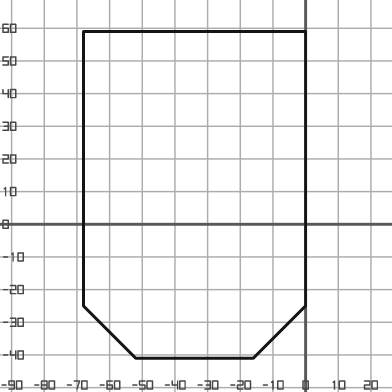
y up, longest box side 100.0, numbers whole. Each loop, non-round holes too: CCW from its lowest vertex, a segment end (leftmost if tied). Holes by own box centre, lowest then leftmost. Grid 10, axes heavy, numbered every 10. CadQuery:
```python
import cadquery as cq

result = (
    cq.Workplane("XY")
    .moveTo(-52.0, -41.0)
    .lineTo(-16.0, -41.0)
    .lineTo(0.0, -25.0)
    .lineTo(0.0, 59.0)
    .lineTo(-68.0, 59.0)
    .lineTo(-68.0, -25.0)
    .close()
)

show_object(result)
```